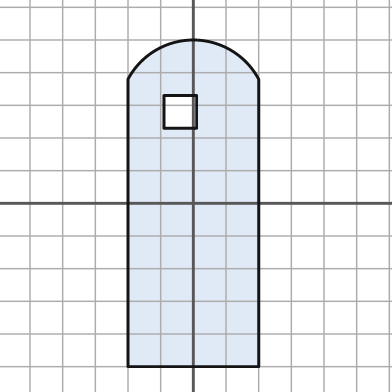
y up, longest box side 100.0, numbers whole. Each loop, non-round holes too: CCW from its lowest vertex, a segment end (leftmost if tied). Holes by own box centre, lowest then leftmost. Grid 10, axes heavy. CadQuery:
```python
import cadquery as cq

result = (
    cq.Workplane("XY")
    .moveTo(-20.0, -50.0)
    .lineTo(20.0, -50.0)
    .lineTo(20.0, 38.0)
    .threePointArc((0.0, 50.0), (-20.0, 38.0))
    .close()
    .moveTo(-9.0, 23.0)
    .lineTo(1.0, 23.0)
    .lineTo(1.0, 33.0)
    .lineTo(-9.0, 33.0)
    .close()
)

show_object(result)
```